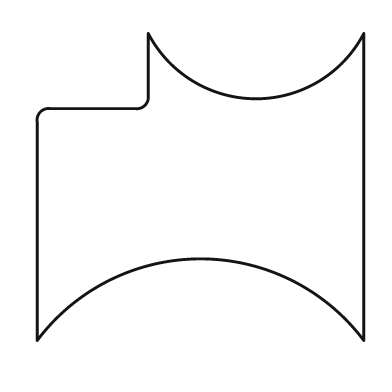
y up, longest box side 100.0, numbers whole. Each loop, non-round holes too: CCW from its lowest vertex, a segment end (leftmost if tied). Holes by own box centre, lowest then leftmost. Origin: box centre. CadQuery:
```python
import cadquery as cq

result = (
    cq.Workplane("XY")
    .moveTo(-50.0, -47.0)
    .threePointArc((0.0, -22.0), (50.0, -47.0))
    .lineTo(50.0, 47.0)
    .threePointArc((17.0, 27.0), (-16.0, 47.0))
    .lineTo(-16.0, 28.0)
    .threePointArc((-17.0, 25.0), (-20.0, 24.0))
    .lineTo(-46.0, 24.0)
    .threePointArc((-49.0, 23.0), (-50.0, 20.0))
    .close()
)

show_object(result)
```